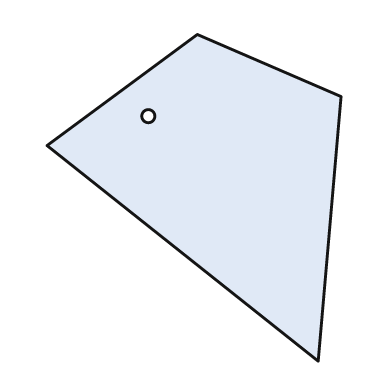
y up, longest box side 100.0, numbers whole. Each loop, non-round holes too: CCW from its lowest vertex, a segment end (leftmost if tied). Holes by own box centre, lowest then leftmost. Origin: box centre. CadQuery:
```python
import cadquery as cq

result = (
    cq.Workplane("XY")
    .moveTo(38.0, -50.0)
    .lineTo(45.0, 31.0)
    .lineTo(1.0, 50.0)
    .lineTo(-45.0, 16.0)
    .close()
    .moveTo(-14.0, 25.0)
    .circle(2.0)
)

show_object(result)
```